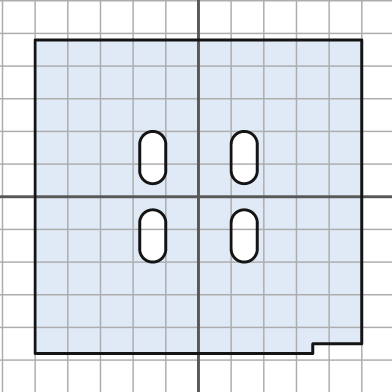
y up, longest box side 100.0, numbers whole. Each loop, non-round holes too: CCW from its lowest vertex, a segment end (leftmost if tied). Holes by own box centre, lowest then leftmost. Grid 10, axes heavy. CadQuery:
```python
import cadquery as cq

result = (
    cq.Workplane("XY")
    .moveTo(-50.0, -48.0)
    .lineTo(35.0, -48.0)
    .lineTo(35.0, -45.0)
    .lineTo(50.0, -45.0)
    .lineTo(50.0, 48.0)
    .lineTo(-50.0, 48.0)
    .close()
    .moveTo(-18.0, -16.0)
    .threePointArc((-14.0, -20.0), (-10.0, -16.0))
    .lineTo(-10.0, -8.0)
    .threePointArc((-14.0, -4.0), (-18.0, -8.0))
    .close()
    .moveTo(10.0, -16.0)
    .threePointArc((14.0, -20.0), (18.0, -16.0))
    .lineTo(18.0, -8.0)
    .threePointArc((14.0, -4.0), (10.0, -8.0))
    .close()
    .moveTo(-18.0, 8.0)
    .threePointArc((-14.0, 4.0), (-10.0, 8.0))
    .lineTo(-10.0, 16.0)
    .threePointArc((-14.0, 20.0), (-18.0, 16.0))
    .close()
    .moveTo(10.0, 8.0)
    .threePointArc((14.0, 4.0), (18.0, 8.0))
    .lineTo(18.0, 16.0)
    .threePointArc((14.0, 20.0), (10.0, 16.0))
    .close()
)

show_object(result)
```